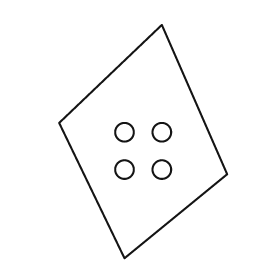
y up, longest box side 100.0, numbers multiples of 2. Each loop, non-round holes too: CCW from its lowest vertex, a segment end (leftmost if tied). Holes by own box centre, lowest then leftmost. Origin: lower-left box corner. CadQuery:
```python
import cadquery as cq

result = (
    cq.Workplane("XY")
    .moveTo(28.0, 0.0)
    .lineTo(72.0, 36.0)
    .lineTo(44.0, 100.0)
    .lineTo(0.0, 58.0)
    .close()
    .moveTo(28.0, 38.0)
    .circle(4.0)
    .moveTo(44.0, 38.0)
    .circle(4.0)
    .moveTo(28.0, 54.0)
    .circle(4.0)
    .moveTo(44.0, 54.0)
    .circle(4.0)
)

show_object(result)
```